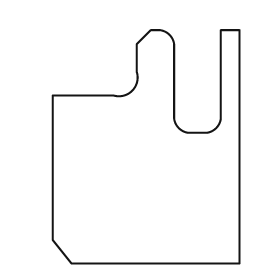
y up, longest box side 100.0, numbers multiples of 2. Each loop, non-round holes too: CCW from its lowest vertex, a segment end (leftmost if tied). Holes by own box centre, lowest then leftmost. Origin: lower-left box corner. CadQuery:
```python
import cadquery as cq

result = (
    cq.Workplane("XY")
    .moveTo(8.0, 0.0)
    .lineTo(80.0, 0.0)
    .lineTo(80.0, 100.0)
    .lineTo(72.0, 100.0)
    .lineTo(72.0, 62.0)
    .threePointArc((70.0, 58.0), (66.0, 56.0))
    .lineTo(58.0, 56.0)
    .threePointArc((54.0, 58.0), (52.0, 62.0))
    .lineTo(52.0, 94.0)
    .threePointArc((50.0, 98.0), (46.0, 100.0))
    .lineTo(42.0, 100.0)
    .lineTo(36.0, 94.0)
    .lineTo(36.0, 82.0)
    .threePointArc((34.0, 74.0), (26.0, 72.0))
    .lineTo(0.0, 72.0)
    .lineTo(0.0, 10.0)
    .close()
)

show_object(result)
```